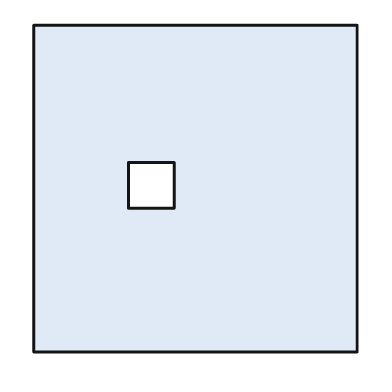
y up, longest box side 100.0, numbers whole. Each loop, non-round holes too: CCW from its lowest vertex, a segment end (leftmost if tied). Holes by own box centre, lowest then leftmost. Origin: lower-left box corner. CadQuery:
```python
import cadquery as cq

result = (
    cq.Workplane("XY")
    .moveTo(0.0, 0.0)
    .lineTo(99.0, 0.0)
    .lineTo(99.0, 100.0)
    .lineTo(0.0, 100.0)
    .close()
    .moveTo(29.0, 44.0)
    .lineTo(43.0, 44.0)
    .lineTo(43.0, 58.0)
    .lineTo(29.0, 58.0)
    .close()
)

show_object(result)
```